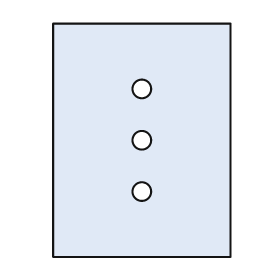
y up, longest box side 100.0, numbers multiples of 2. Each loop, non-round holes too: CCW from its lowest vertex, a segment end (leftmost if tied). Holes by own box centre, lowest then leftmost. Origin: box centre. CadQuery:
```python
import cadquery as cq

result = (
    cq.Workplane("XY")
    .moveTo(-38.0, -50.0)
    .lineTo(38.0, -50.0)
    .lineTo(38.0, 50.0)
    .lineTo(-38.0, 50.0)
    .close()
    .moveTo(0.0, -22.0)
    .circle(4.0)
    .moveTo(0.0, 0.0)
    .circle(4.0)
    .moveTo(0.0, 22.0)
    .circle(4.0)
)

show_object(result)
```